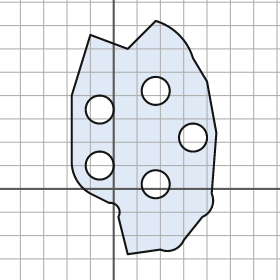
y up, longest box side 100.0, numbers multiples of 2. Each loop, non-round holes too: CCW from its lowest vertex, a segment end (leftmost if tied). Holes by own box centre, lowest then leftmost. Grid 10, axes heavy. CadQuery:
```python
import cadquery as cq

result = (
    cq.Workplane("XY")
    .moveTo(6.0, -28.0)
    .lineTo(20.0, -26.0)
    .threePointArc((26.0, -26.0), (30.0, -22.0))
    .lineTo(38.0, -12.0)
    .threePointArc((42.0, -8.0), (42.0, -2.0))
    .lineTo(44.0, 24.0)
    .lineTo(40.0, 46.0)
    .lineTo(34.0, 56.0)
    .threePointArc((28.0, 66.0), (18.0, 72.0))
    .lineTo(6.0, 60.0)
    .lineTo(-10.0, 66.0)
    .lineTo(-18.0, 40.0)
    .lineTo(-18.0, 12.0)
    .threePointArc((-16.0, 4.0), (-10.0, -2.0))
    .lineTo(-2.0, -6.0)
    .threePointArc((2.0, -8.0), (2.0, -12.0))
    .close()
    .moveTo(18.0, 2.0)
    .circle(6.0)
    .moveTo(-6.0, 10.0)
    .circle(6.0)
    .moveTo(34.0, 22.0)
    .circle(6.0)
    .moveTo(-6.0, 34.0)
    .circle(6.0)
    .moveTo(18.0, 42.0)
    .circle(6.0)
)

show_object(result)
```